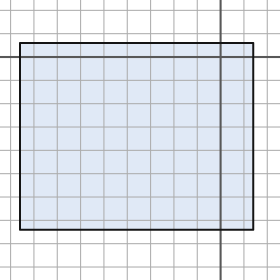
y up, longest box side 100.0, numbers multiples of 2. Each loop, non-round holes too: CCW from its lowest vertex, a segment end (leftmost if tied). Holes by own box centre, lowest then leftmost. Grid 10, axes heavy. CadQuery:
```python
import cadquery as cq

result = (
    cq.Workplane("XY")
    .moveTo(-86.0, -74.0)
    .lineTo(14.0, -74.0)
    .lineTo(14.0, 6.0)
    .lineTo(-86.0, 6.0)
    .close()
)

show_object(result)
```